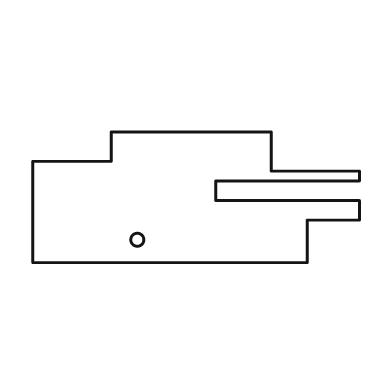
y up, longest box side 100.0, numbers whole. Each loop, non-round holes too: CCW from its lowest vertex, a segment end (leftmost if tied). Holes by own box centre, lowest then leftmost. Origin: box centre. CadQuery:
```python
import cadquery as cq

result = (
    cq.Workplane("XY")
    .moveTo(-50.0, -20.0)
    .lineTo(34.0, -20.0)
    .lineTo(34.0, -7.0)
    .lineTo(50.0, -7.0)
    .lineTo(50.0, -1.0)
    .lineTo(6.0, -1.0)
    .lineTo(6.0, 5.0)
    .lineTo(50.0, 5.0)
    .lineTo(50.0, 8.0)
    .lineTo(23.0, 8.0)
    .lineTo(23.0, 20.0)
    .lineTo(-26.0, 20.0)
    .lineTo(-26.0, 11.0)
    .lineTo(-50.0, 11.0)
    .close()
    .moveTo(-18.0, -13.0)
    .circle(2.0)
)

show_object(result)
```